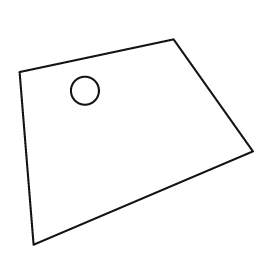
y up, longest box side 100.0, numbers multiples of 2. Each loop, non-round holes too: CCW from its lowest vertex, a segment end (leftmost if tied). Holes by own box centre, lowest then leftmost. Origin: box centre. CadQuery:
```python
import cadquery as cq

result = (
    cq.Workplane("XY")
    .moveTo(-44.0, -44.0)
    .lineTo(50.0, -4.0)
    .lineTo(16.0, 44.0)
    .lineTo(-50.0, 30.0)
    .close()
    .moveTo(-22.0, 22.0)
    .circle(6.0)
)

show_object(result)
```